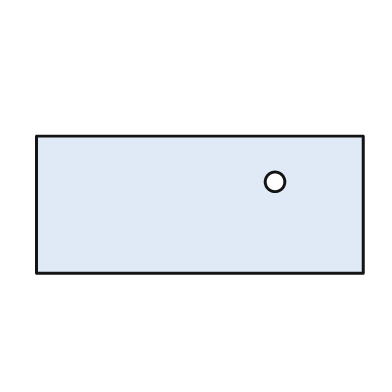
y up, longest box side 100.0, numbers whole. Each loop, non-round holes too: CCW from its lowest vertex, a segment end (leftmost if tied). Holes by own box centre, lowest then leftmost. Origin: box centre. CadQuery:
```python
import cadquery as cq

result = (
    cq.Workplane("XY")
    .moveTo(-50.0, -21.0)
    .lineTo(50.0, -21.0)
    .lineTo(50.0, 21.0)
    .lineTo(-50.0, 21.0)
    .close()
    .moveTo(23.0, 7.0)
    .circle(3.0)
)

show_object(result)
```